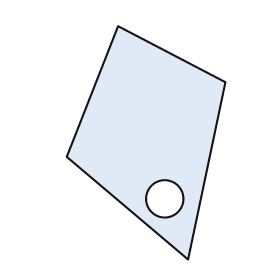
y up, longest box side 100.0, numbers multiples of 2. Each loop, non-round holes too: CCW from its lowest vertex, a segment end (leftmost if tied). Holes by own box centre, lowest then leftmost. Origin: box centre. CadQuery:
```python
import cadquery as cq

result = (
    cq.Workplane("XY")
    .moveTo(18.0, -50.0)
    .lineTo(34.0, 26.0)
    .lineTo(-12.0, 50.0)
    .lineTo(-34.0, -6.0)
    .close()
    .moveTo(8.0, -24.0)
    .circle(8.0)
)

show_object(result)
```